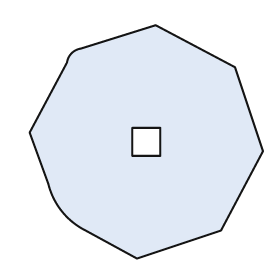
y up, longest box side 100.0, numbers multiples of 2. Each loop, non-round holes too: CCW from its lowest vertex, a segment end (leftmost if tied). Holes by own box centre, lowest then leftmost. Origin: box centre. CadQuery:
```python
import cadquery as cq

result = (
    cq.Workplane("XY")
    .moveTo(-4.0, -50.0)
    .lineTo(32.0, -38.0)
    .lineTo(50.0, -4.0)
    .lineTo(38.0, 32.0)
    .lineTo(4.0, 50.0)
    .lineTo(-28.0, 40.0)
    .threePointArc((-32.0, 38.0), (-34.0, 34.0))
    .lineTo(-50.0, 4.0)
    .lineTo(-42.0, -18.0)
    .threePointArc((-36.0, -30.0), (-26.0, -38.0))
    .close()
    .moveTo(-6.0, -6.0)
    .lineTo(6.0, -6.0)
    .lineTo(6.0, 6.0)
    .lineTo(-6.0, 6.0)
    .close()
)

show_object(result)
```